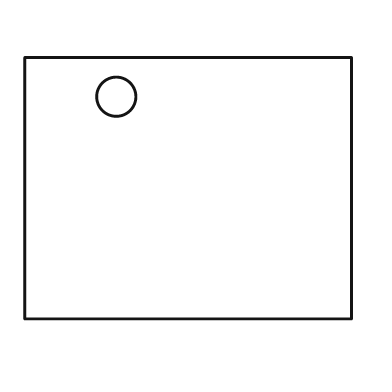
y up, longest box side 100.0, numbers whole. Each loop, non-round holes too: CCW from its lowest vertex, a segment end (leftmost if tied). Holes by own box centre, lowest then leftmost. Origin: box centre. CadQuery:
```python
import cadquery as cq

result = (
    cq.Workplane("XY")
    .moveTo(-50.0, -40.0)
    .lineTo(50.0, -40.0)
    .lineTo(50.0, 40.0)
    .lineTo(-50.0, 40.0)
    .close()
    .moveTo(-22.0, 28.0)
    .circle(6.0)
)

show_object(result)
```